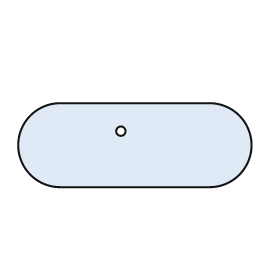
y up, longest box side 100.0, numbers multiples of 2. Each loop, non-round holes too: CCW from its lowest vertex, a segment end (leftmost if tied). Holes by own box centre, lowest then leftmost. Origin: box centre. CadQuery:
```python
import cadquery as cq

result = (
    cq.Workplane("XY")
    .moveTo(-32.0, -18.0)
    .lineTo(32.0, -18.0)
    .threePointArc((50.0, 0.0), (32.0, 18.0))
    .lineTo(-32.0, 18.0)
    .threePointArc((-50.0, 0.0), (-32.0, -18.0))
    .close()
    .moveTo(-6.0, 6.0)
    .circle(2.0)
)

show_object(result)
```